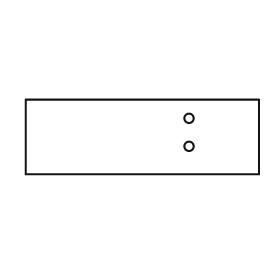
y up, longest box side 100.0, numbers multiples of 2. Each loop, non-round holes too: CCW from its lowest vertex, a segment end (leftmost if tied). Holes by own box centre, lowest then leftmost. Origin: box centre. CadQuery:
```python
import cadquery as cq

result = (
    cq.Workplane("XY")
    .moveTo(-50.0, -16.0)
    .lineTo(50.0, -16.0)
    .lineTo(50.0, 16.0)
    .lineTo(-50.0, 16.0)
    .close()
    .moveTo(20.0, -4.0)
    .circle(2.0)
    .moveTo(20.0, 8.0)
    .circle(2.0)
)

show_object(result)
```